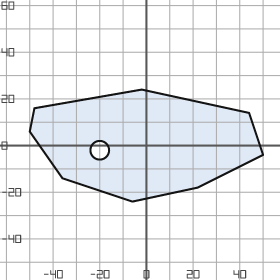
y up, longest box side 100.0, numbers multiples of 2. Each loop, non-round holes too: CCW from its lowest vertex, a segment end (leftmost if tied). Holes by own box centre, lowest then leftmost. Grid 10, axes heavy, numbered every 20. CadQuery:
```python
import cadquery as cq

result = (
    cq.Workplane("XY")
    .moveTo(-6.0, -24.0)
    .lineTo(22.0, -18.0)
    .lineTo(50.0, -4.0)
    .lineTo(44.0, 14.0)
    .lineTo(-2.0, 24.0)
    .lineTo(-48.0, 16.0)
    .lineTo(-50.0, 6.0)
    .lineTo(-36.0, -14.0)
    .close()
    .moveTo(-20.0, -2.0)
    .circle(4.0)
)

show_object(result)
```